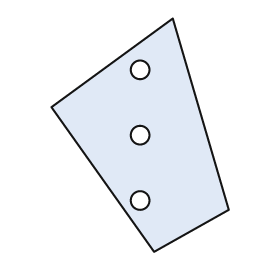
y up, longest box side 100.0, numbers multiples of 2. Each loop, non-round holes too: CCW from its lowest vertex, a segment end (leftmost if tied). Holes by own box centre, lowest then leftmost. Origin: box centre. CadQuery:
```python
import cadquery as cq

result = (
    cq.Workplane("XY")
    .moveTo(6.0, -50.0)
    .lineTo(38.0, -32.0)
    .lineTo(14.0, 50.0)
    .lineTo(-38.0, 12.0)
    .close()
    .moveTo(0.0, -28.0)
    .circle(4.0)
    .moveTo(0.0, 0.0)
    .circle(4.0)
    .moveTo(0.0, 28.0)
    .circle(4.0)
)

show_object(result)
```